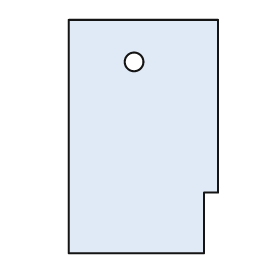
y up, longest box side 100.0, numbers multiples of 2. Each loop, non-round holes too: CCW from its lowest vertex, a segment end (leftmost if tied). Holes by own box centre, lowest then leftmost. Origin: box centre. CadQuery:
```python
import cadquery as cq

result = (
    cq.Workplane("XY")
    .moveTo(-32.0, -50.0)
    .lineTo(26.0, -50.0)
    .lineTo(26.0, -24.0)
    .lineTo(32.0, -24.0)
    .lineTo(32.0, 50.0)
    .lineTo(-32.0, 50.0)
    .close()
    .moveTo(-4.0, 32.0)
    .circle(4.0)
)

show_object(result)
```